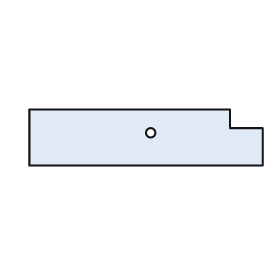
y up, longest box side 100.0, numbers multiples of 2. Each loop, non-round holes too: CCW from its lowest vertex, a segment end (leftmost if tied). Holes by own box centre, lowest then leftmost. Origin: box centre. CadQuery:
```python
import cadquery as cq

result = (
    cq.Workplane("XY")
    .moveTo(-50.0, -12.0)
    .lineTo(50.0, -12.0)
    .lineTo(50.0, 4.0)
    .lineTo(36.0, 4.0)
    .lineTo(36.0, 12.0)
    .lineTo(-50.0, 12.0)
    .close()
    .moveTo(2.0, 2.0)
    .circle(2.0)
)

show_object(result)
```